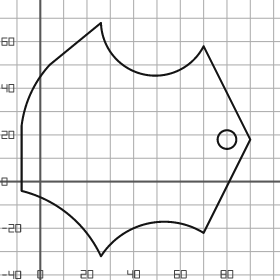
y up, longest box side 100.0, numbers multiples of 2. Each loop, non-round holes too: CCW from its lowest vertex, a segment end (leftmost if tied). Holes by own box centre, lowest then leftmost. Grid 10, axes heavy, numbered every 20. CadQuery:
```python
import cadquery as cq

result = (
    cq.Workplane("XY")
    .moveTo(26.0, -32.0)
    .threePointArc((46.0, -18.0), (70.0, -22.0))
    .lineTo(90.0, 18.0)
    .lineTo(70.0, 58.0)
    .threePointArc((44.0, 46.0), (26.0, 68.0))
    .lineTo(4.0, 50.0)
    .threePointArc((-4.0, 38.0), (-8.0, 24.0))
    .lineTo(-8.0, -4.0)
    .threePointArc((12.0, -14.0), (26.0, -32.0))
    .close()
    .moveTo(80.0, 18.0)
    .circle(4.0)
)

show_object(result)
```